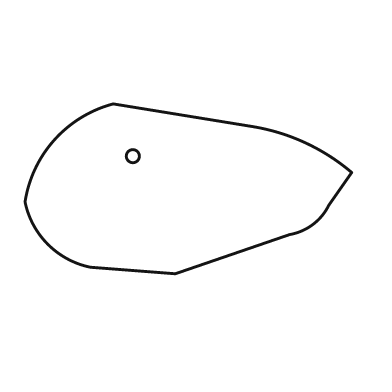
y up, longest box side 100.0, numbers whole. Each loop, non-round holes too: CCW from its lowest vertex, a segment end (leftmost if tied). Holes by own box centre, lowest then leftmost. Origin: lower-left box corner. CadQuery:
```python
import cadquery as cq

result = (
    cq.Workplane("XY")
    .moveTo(46.0, 0.0)
    .lineTo(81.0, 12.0)
    .threePointArc((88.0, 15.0), (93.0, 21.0))
    .lineTo(100.0, 31.0)
    .threePointArc((86.0, 40.0), (70.0, 45.0))
    .lineTo(27.0, 52.0)
    .threePointArc((9.0, 41.0), (0.0, 22.0))
    .threePointArc((7.0, 9.0), (20.0, 2.0))
    .close()
    .moveTo(33.0, 36.0)
    .circle(2.0)
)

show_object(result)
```